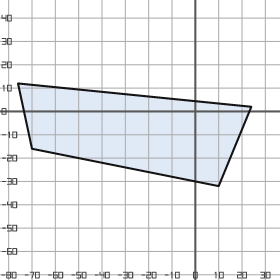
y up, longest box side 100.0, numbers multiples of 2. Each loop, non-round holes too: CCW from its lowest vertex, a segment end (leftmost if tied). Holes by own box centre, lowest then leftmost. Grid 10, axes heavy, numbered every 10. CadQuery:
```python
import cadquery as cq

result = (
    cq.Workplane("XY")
    .moveTo(10.0, -32.0)
    .lineTo(24.0, 2.0)
    .lineTo(-76.0, 12.0)
    .lineTo(-70.0, -16.0)
    .close()
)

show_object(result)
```